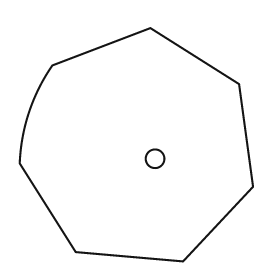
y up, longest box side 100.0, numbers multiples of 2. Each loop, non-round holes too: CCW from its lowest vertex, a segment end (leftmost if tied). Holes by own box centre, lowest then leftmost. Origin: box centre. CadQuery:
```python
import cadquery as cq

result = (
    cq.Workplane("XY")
    .moveTo(20.0, -50.0)
    .lineTo(50.0, -18.0)
    .lineTo(44.0, 26.0)
    .lineTo(6.0, 50.0)
    .lineTo(-36.0, 34.0)
    .threePointArc((-46.0, 14.0), (-50.0, -8.0))
    .lineTo(-26.0, -46.0)
    .close()
    .moveTo(8.0, -6.0)
    .circle(4.0)
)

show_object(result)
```